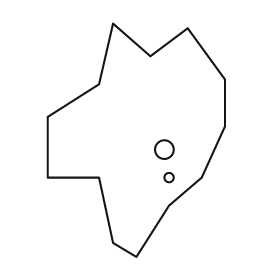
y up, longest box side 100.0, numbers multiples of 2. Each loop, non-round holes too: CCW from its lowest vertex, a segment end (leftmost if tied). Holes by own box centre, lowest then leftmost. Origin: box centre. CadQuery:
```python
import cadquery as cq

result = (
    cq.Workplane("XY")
    .moveTo(0.0, -50.0)
    .lineTo(14.0, -28.0)
    .lineTo(28.0, -16.0)
    .lineTo(38.0, 6.0)
    .lineTo(38.0, 26.0)
    .lineTo(22.0, 48.0)
    .lineTo(6.0, 36.0)
    .lineTo(-10.0, 50.0)
    .lineTo(-16.0, 24.0)
    .lineTo(-38.0, 10.0)
    .lineTo(-38.0, -16.0)
    .lineTo(-16.0, -16.0)
    .lineTo(-10.0, -44.0)
    .close()
    .moveTo(14.0, -16.0)
    .circle(2.0)
    .moveTo(12.0, -4.0)
    .circle(4.0)
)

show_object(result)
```